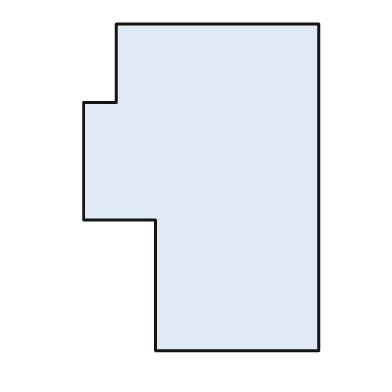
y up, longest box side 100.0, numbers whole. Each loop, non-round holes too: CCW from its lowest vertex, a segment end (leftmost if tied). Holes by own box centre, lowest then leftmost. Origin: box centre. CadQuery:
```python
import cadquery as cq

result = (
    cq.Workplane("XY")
    .moveTo(-14.0, -50.0)
    .lineTo(36.0, -50.0)
    .lineTo(36.0, 50.0)
    .lineTo(-26.0, 50.0)
    .lineTo(-26.0, 26.0)
    .lineTo(-36.0, 26.0)
    .lineTo(-36.0, -10.0)
    .lineTo(-14.0, -10.0)
    .close()
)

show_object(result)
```